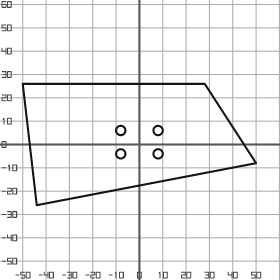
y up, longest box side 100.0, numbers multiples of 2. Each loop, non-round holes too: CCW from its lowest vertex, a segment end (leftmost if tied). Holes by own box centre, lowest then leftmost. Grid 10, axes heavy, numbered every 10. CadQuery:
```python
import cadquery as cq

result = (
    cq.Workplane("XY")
    .moveTo(-44.0, -26.0)
    .lineTo(50.0, -8.0)
    .lineTo(28.0, 26.0)
    .lineTo(-50.0, 26.0)
    .close()
    .moveTo(-8.0, -4.0)
    .circle(2.0)
    .moveTo(8.0, -4.0)
    .circle(2.0)
    .moveTo(-8.0, 6.0)
    .circle(2.0)
    .moveTo(8.0, 6.0)
    .circle(2.0)
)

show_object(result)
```